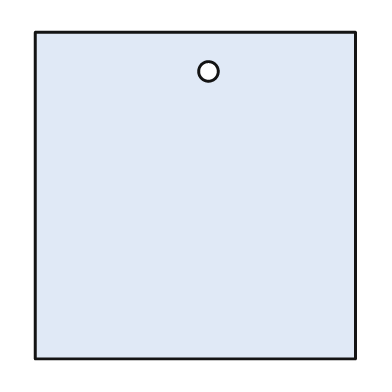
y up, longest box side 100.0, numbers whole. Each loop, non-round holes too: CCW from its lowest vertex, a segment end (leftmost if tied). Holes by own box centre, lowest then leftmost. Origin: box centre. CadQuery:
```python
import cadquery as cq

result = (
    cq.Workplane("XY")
    .moveTo(-49.0, -50.0)
    .lineTo(49.0, -50.0)
    .lineTo(49.0, 50.0)
    .lineTo(-49.0, 50.0)
    .close()
    .moveTo(4.0, 38.0)
    .circle(3.0)
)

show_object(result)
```